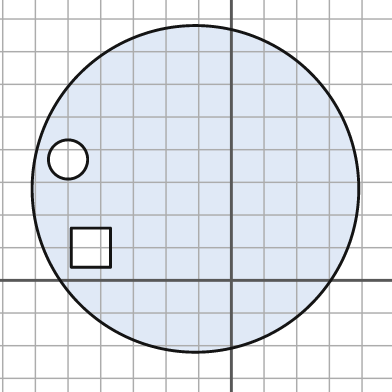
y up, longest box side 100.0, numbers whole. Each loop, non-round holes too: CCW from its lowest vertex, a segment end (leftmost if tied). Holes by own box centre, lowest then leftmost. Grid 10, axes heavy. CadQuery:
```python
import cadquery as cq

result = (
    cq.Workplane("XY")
    .moveTo(-11.0, 28.0)
    .circle(50.0)
    .moveTo(-49.0, 4.0)
    .lineTo(-37.0, 4.0)
    .lineTo(-37.0, 16.0)
    .lineTo(-49.0, 16.0)
    .close()
    .moveTo(-50.0, 37.0)
    .circle(6.0)
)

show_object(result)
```